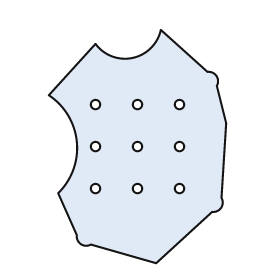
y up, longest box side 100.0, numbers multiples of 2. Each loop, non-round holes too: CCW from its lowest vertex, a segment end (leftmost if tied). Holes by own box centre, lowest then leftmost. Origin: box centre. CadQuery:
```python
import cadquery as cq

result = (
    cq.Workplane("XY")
    .moveTo(8.0, -50.0)
    .lineTo(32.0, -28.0)
    .threePointArc((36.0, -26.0), (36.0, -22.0))
    .lineTo(38.0, 10.0)
    .lineTo(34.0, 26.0)
    .threePointArc((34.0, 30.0), (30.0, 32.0))
    .lineTo(10.0, 50.0)
    .threePointArc((-2.0, 38.0), (-18.0, 44.0))
    .lineTo(-38.0, 22.0)
    .threePointArc((-26.0, 2.0), (-34.0, -20.0))
    .lineTo(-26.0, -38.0)
    .threePointArc((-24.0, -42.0), (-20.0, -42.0))
    .close()
    .moveTo(-18.0, -18.0)
    .circle(2.0)
    .moveTo(0.0, -18.0)
    .circle(2.0)
    .moveTo(18.0, -18.0)
    .circle(2.0)
    .moveTo(-18.0, 0.0)
    .circle(2.0)
    .moveTo(0.0, 0.0)
    .circle(2.0)
    .moveTo(18.0, 0.0)
    .circle(2.0)
    .moveTo(-18.0, 18.0)
    .circle(2.0)
    .moveTo(0.0, 18.0)
    .circle(2.0)
    .moveTo(18.0, 18.0)
    .circle(2.0)
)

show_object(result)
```